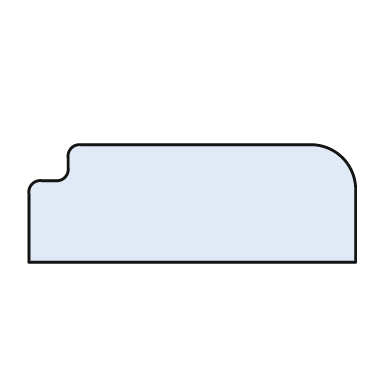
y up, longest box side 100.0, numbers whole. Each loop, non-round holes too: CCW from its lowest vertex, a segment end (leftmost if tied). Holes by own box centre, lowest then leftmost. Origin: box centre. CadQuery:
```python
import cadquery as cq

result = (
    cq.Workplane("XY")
    .moveTo(-50.0, -18.0)
    .lineTo(50.0, -18.0)
    .lineTo(50.0, 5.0)
    .threePointArc((46.0, 14.0), (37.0, 18.0))
    .lineTo(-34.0, 18.0)
    .threePointArc((-37.0, 17.0), (-38.0, 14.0))
    .lineTo(-38.0, 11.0)
    .threePointArc((-39.0, 8.0), (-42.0, 7.0))
    .lineTo(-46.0, 7.0)
    .threePointArc((-49.0, 6.0), (-50.0, 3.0))
    .close()
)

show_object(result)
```